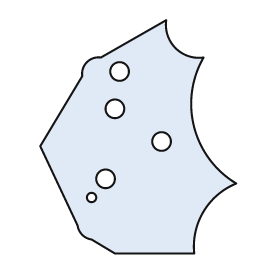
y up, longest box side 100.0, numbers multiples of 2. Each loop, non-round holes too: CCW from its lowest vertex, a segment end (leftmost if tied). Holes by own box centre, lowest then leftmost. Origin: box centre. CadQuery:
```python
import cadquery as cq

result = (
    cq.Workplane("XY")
    .moveTo(-10.0, -50.0)
    .lineTo(24.0, -50.0)
    .threePointArc((28.0, -32.0), (42.0, -20.0))
    .threePointArc((24.0, 4.0), (28.0, 34.0))
    .threePointArc((16.0, 38.0), (12.0, 50.0))
    .lineTo(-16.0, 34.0)
    .threePointArc((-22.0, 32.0), (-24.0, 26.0))
    .lineTo(-42.0, -4.0)
    .lineTo(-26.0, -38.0)
    .threePointArc((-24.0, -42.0), (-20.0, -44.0))
    .close()
    .moveTo(-20.0, -26.0)
    .circle(2.0)
    .moveTo(-14.0, -18.0)
    .circle(4.0)
    .moveTo(10.0, -2.0)
    .circle(4.0)
    .moveTo(-10.0, 12.0)
    .circle(4.0)
    .moveTo(-8.0, 28.0)
    .circle(4.0)
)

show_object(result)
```